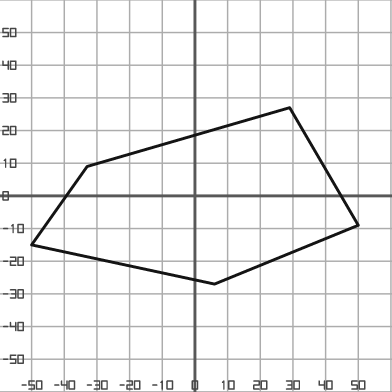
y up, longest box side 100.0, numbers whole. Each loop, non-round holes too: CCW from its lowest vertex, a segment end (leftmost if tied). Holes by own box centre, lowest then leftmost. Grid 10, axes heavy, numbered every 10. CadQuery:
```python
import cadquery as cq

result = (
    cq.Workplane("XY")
    .moveTo(6.0, -27.0)
    .lineTo(50.0, -9.0)
    .lineTo(29.0, 27.0)
    .lineTo(-33.0, 9.0)
    .lineTo(-50.0, -15.0)
    .close()
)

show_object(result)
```